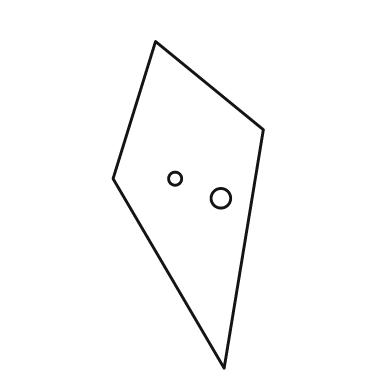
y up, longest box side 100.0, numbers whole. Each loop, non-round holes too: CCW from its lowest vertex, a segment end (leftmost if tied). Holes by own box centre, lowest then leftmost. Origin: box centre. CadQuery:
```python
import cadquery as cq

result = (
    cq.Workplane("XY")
    .moveTo(11.0, -50.0)
    .lineTo(23.0, 23.0)
    .lineTo(-10.0, 50.0)
    .lineTo(-23.0, 8.0)
    .close()
    .moveTo(10.0, 2.0)
    .circle(3.0)
    .moveTo(-4.0, 8.0)
    .circle(2.0)
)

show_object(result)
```